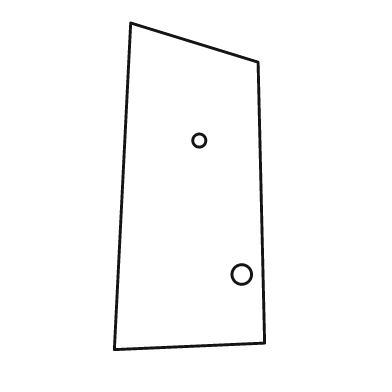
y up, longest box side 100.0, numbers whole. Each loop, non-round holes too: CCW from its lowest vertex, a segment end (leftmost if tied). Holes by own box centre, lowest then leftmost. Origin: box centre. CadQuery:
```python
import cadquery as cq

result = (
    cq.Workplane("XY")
    .moveTo(-23.0, -50.0)
    .lineTo(23.0, -48.0)
    .lineTo(21.0, 38.0)
    .lineTo(-18.0, 50.0)
    .close()
    .moveTo(16.0, -27.0)
    .circle(3.0)
    .moveTo(3.0, 14.0)
    .circle(2.0)
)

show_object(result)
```